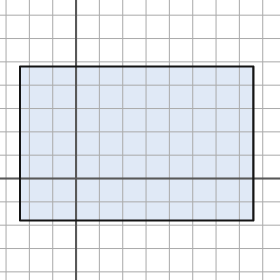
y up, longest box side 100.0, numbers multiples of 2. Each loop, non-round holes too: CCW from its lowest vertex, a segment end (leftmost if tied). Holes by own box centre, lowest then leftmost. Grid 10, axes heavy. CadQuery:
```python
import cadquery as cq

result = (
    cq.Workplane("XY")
    .moveTo(-24.0, -18.0)
    .lineTo(76.0, -18.0)
    .lineTo(76.0, 48.0)
    .lineTo(-24.0, 48.0)
    .close()
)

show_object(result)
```